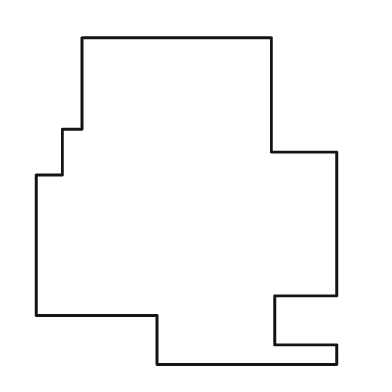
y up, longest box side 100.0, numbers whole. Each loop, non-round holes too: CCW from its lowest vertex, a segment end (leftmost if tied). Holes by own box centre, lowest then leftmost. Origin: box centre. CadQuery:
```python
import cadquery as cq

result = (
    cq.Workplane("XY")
    .moveTo(-9.0, -50.0)
    .lineTo(46.0, -50.0)
    .lineTo(46.0, -44.0)
    .lineTo(27.0, -44.0)
    .lineTo(27.0, -29.0)
    .lineTo(46.0, -29.0)
    .lineTo(46.0, 15.0)
    .lineTo(26.0, 15.0)
    .lineTo(26.0, 50.0)
    .lineTo(-32.0, 50.0)
    .lineTo(-32.0, 22.0)
    .lineTo(-38.0, 22.0)
    .lineTo(-38.0, 8.0)
    .lineTo(-46.0, 8.0)
    .lineTo(-46.0, -35.0)
    .lineTo(-9.0, -35.0)
    .close()
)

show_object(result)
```